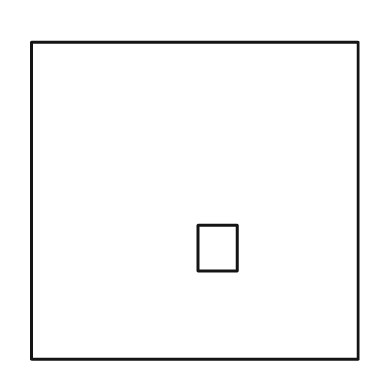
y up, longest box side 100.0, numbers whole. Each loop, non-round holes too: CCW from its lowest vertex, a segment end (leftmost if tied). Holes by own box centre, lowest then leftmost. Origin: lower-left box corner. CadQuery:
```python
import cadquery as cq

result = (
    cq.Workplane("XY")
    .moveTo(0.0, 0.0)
    .lineTo(100.0, 0.0)
    .lineTo(100.0, 97.0)
    .lineTo(0.0, 97.0)
    .close()
    .moveTo(51.0, 27.0)
    .lineTo(63.0, 27.0)
    .lineTo(63.0, 41.0)
    .lineTo(51.0, 41.0)
    .close()
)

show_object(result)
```